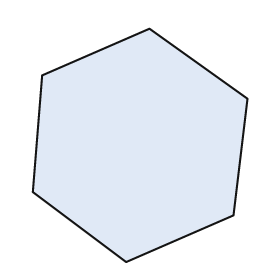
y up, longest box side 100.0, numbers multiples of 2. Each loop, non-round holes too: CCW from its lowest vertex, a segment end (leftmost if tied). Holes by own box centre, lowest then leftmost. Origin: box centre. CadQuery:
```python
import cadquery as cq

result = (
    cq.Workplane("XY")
    .moveTo(-6.0, -50.0)
    .lineTo(40.0, -30.0)
    .lineTo(46.0, 20.0)
    .lineTo(4.0, 50.0)
    .lineTo(-42.0, 30.0)
    .lineTo(-46.0, -20.0)
    .close()
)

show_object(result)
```